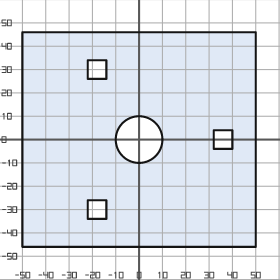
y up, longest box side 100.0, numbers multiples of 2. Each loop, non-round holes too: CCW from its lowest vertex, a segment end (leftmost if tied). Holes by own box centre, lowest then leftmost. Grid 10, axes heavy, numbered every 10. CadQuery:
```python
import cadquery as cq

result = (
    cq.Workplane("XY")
    .moveTo(-50.0, -46.0)
    .lineTo(50.0, -46.0)
    .lineTo(50.0, 46.0)
    .lineTo(-50.0, 46.0)
    .close()
    .moveTo(-22.0, -34.0)
    .lineTo(-14.0, -34.0)
    .lineTo(-14.0, -26.0)
    .lineTo(-22.0, -26.0)
    .close()
    .moveTo(0.0, 0.0)
    .circle(10.0)
    .moveTo(32.0, -4.0)
    .lineTo(40.0, -4.0)
    .lineTo(40.0, 4.0)
    .lineTo(32.0, 4.0)
    .close()
    .moveTo(-22.0, 26.0)
    .lineTo(-14.0, 26.0)
    .lineTo(-14.0, 34.0)
    .lineTo(-22.0, 34.0)
    .close()
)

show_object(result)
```